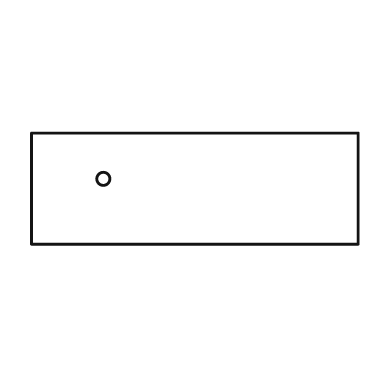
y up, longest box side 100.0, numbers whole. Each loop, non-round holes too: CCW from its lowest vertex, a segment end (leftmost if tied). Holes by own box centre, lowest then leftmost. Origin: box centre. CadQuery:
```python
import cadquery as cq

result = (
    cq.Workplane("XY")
    .moveTo(-50.0, -17.0)
    .lineTo(50.0, -17.0)
    .lineTo(50.0, 17.0)
    .lineTo(-50.0, 17.0)
    .close()
    .moveTo(-28.0, 3.0)
    .circle(2.0)
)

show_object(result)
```